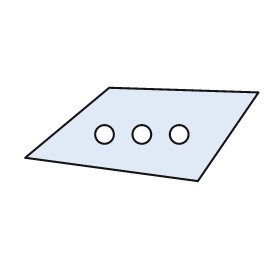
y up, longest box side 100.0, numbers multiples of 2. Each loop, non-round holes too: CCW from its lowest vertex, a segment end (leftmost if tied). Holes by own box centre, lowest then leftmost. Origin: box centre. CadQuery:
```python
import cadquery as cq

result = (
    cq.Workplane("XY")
    .moveTo(24.0, -20.0)
    .lineTo(50.0, 18.0)
    .lineTo(-14.0, 20.0)
    .lineTo(-50.0, -10.0)
    .close()
    .moveTo(-16.0, 0.0)
    .circle(4.0)
    .moveTo(0.0, 0.0)
    .circle(4.0)
    .moveTo(16.0, 0.0)
    .circle(4.0)
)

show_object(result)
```